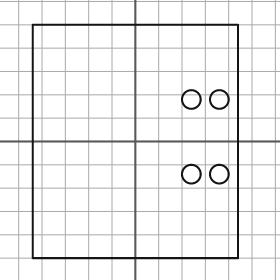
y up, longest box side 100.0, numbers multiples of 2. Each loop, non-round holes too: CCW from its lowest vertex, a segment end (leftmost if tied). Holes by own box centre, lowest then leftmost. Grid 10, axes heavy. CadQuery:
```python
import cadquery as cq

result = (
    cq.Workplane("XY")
    .moveTo(-44.0, -50.0)
    .lineTo(44.0, -50.0)
    .lineTo(44.0, 50.0)
    .lineTo(-44.0, 50.0)
    .close()
    .moveTo(24.0, -14.0)
    .circle(4.0)
    .moveTo(36.0, -14.0)
    .circle(4.0)
    .moveTo(24.0, 18.0)
    .circle(4.0)
    .moveTo(36.0, 18.0)
    .circle(4.0)
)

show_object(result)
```